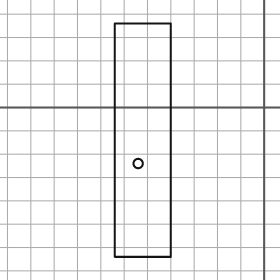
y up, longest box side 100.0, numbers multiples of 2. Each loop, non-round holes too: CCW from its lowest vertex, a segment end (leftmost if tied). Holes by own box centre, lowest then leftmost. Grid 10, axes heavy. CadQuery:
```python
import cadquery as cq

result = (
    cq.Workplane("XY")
    .moveTo(-64.0, -64.0)
    .lineTo(-40.0, -64.0)
    .lineTo(-40.0, 36.0)
    .lineTo(-64.0, 36.0)
    .close()
    .moveTo(-54.0, -24.0)
    .circle(2.0)
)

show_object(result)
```